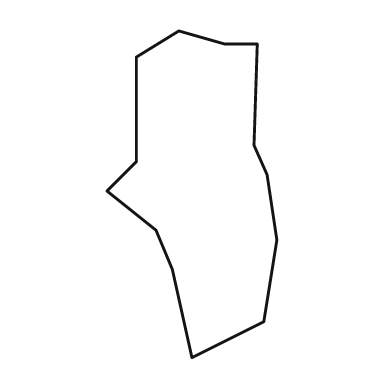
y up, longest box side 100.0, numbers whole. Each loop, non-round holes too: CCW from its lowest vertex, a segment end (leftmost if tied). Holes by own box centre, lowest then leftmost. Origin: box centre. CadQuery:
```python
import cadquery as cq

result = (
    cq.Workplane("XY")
    .moveTo(0.0, -50.0)
    .lineTo(22.0, -39.0)
    .lineTo(26.0, -14.0)
    .lineTo(23.0, 6.0)
    .lineTo(19.0, 15.0)
    .lineTo(20.0, 46.0)
    .lineTo(10.0, 46.0)
    .lineTo(-4.0, 50.0)
    .lineTo(-17.0, 42.0)
    .lineTo(-17.0, 10.0)
    .lineTo(-26.0, 1.0)
    .lineTo(-11.0, -11.0)
    .lineTo(-6.0, -23.0)
    .close()
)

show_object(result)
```